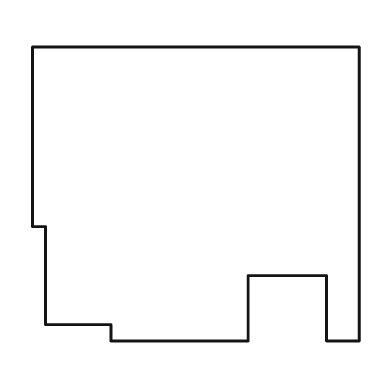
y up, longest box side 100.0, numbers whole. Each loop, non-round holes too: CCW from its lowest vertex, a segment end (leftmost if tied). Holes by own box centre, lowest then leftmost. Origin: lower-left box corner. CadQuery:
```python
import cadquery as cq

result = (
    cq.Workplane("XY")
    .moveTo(24.0, 0.0)
    .lineTo(66.0, 0.0)
    .lineTo(66.0, 20.0)
    .lineTo(90.0, 20.0)
    .lineTo(90.0, 0.0)
    .lineTo(100.0, 0.0)
    .lineTo(100.0, 90.0)
    .lineTo(0.0, 90.0)
    .lineTo(0.0, 35.0)
    .lineTo(4.0, 35.0)
    .lineTo(4.0, 5.0)
    .lineTo(24.0, 5.0)
    .close()
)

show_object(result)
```